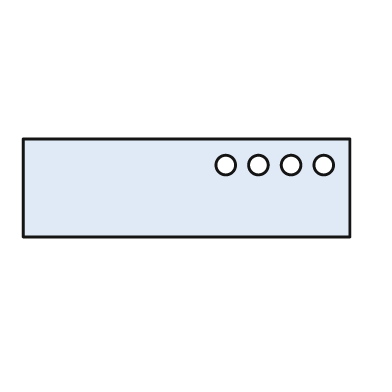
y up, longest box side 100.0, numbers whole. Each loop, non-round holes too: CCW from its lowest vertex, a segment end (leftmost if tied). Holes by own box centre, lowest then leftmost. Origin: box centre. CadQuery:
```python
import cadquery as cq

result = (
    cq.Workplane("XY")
    .moveTo(-50.0, -15.0)
    .lineTo(50.0, -15.0)
    .lineTo(50.0, 15.0)
    .lineTo(-50.0, 15.0)
    .close()
    .moveTo(12.0, 7.0)
    .circle(3.0)
    .moveTo(22.0, 7.0)
    .circle(3.0)
    .moveTo(32.0, 7.0)
    .circle(3.0)
    .moveTo(42.0, 7.0)
    .circle(3.0)
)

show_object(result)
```